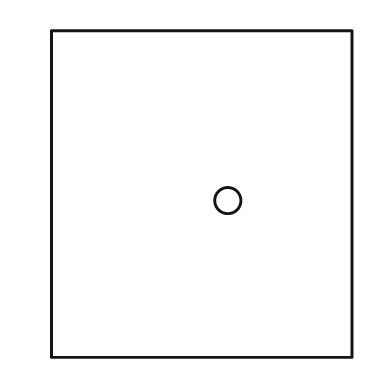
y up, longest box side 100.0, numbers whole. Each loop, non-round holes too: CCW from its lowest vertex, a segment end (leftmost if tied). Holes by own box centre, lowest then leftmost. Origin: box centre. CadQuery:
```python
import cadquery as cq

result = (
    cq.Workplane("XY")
    .moveTo(-46.0, -50.0)
    .lineTo(46.0, -50.0)
    .lineTo(46.0, 50.0)
    .lineTo(-46.0, 50.0)
    .close()
    .moveTo(8.0, -2.0)
    .circle(4.0)
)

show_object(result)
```